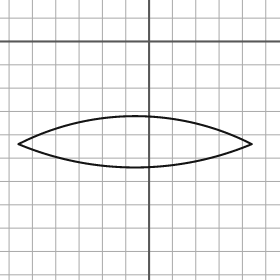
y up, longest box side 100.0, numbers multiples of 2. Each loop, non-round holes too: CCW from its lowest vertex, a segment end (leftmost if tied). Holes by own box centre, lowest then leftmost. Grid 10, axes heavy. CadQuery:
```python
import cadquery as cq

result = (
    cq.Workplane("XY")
    .moveTo(-56.0, -44.0)
    .threePointArc((-6.0, -54.0), (44.0, -44.0))
    .threePointArc((-6.0, -32.0), (-56.0, -44.0))
    .close()
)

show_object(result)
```